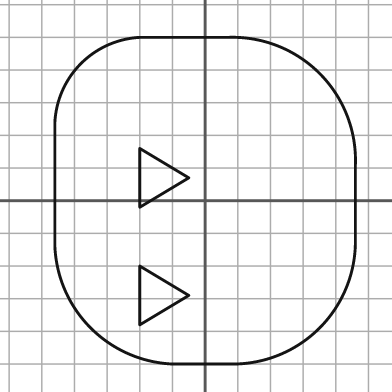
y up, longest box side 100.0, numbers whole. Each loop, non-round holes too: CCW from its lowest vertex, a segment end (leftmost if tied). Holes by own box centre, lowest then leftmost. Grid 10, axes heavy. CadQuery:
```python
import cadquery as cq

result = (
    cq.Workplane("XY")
    .moveTo(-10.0, -50.0)
    .lineTo(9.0, -50.0)
    .threePointArc((35.0, -39.0), (46.0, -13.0))
    .lineTo(46.0, 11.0)
    .threePointArc((35.0, 39.0), (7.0, 50.0))
    .lineTo(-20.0, 50.0)
    .threePointArc((-38.0, 42.0), (-46.0, 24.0))
    .lineTo(-46.0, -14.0)
    .threePointArc((-35.0, -39.0), (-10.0, -50.0))
    .close()
    .moveTo(-20.0, -38.0)
    .lineTo(-5.0, -29.0)
    .lineTo(-20.0, -20.0)
    .close()
    .moveTo(-20.0, -2.0)
    .lineTo(-5.0, 7.0)
    .lineTo(-20.0, 16.0)
    .close()
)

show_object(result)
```